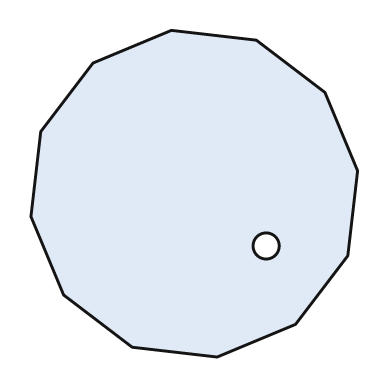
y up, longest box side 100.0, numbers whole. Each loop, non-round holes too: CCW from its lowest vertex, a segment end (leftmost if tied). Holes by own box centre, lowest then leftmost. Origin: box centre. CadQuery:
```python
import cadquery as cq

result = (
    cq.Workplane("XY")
    .moveTo(7.0, -50.0)
    .lineTo(31.0, -40.0)
    .lineTo(47.0, -19.0)
    .lineTo(50.0, 7.0)
    .lineTo(40.0, 31.0)
    .lineTo(19.0, 47.0)
    .lineTo(-7.0, 50.0)
    .lineTo(-31.0, 40.0)
    .lineTo(-47.0, 19.0)
    .lineTo(-50.0, -7.0)
    .lineTo(-40.0, -31.0)
    .lineTo(-19.0, -47.0)
    .close()
    .moveTo(22.0, -16.0)
    .circle(4.0)
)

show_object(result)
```